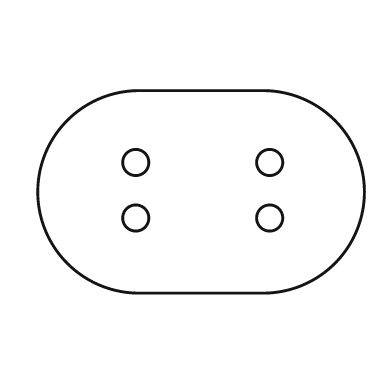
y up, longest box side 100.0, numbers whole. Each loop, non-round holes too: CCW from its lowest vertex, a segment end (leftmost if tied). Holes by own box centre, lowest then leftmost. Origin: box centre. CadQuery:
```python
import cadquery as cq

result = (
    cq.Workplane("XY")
    .moveTo(-19.0, -31.0)
    .lineTo(19.0, -31.0)
    .threePointArc((50.0, 0.0), (19.0, 31.0))
    .lineTo(-19.0, 31.0)
    .threePointArc((-50.0, 0.0), (-19.0, -31.0))
    .close()
    .moveTo(-20.0, -8.0)
    .circle(4.0)
    .moveTo(21.0, -8.0)
    .circle(4.0)
    .moveTo(-20.0, 9.0)
    .circle(4.0)
    .moveTo(21.0, 9.0)
    .circle(4.0)
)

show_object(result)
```